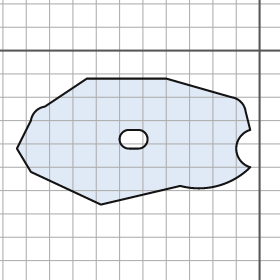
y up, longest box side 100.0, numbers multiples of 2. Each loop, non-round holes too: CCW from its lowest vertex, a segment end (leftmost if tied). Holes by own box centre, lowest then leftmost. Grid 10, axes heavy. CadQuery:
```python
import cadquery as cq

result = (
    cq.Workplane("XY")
    .moveTo(-68.0, -66.0)
    .lineTo(-34.0, -58.0)
    .threePointArc((-18.0, -58.0), (-4.0, -50.0))
    .threePointArc((-10.0, -42.0), (-4.0, -34.0))
    .lineTo(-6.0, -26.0)
    .threePointArc((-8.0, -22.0), (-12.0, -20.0))
    .lineTo(-40.0, -12.0)
    .lineTo(-74.0, -12.0)
    .lineTo(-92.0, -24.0)
    .threePointArc((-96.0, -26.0), (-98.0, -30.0))
    .lineTo(-104.0, -42.0)
    .lineTo(-98.0, -52.0)
    .close()
    .moveTo(-56.0, -42.0)
    .lineTo(-52.0, -42.0)
    .threePointArc((-48.0, -38.0), (-52.0, -34.0))
    .lineTo(-56.0, -34.0)
    .threePointArc((-60.0, -38.0), (-56.0, -42.0))
    .close()
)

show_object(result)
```